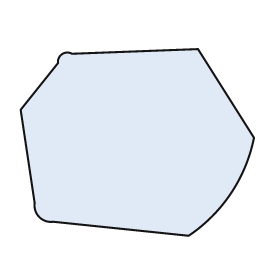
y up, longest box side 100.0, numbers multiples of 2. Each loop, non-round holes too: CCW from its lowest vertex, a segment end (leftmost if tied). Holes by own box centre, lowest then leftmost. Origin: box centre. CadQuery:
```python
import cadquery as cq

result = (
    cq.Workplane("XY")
    .moveTo(22.0, -40.0)
    .threePointArc((40.0, -22.0), (50.0, 2.0))
    .lineTo(26.0, 40.0)
    .lineTo(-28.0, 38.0)
    .threePointArc((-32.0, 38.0), (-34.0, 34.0))
    .lineTo(-50.0, 14.0)
    .lineTo(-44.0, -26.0)
    .threePointArc((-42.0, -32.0), (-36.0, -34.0))
    .close()
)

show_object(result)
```